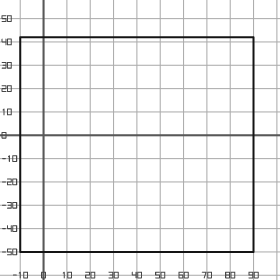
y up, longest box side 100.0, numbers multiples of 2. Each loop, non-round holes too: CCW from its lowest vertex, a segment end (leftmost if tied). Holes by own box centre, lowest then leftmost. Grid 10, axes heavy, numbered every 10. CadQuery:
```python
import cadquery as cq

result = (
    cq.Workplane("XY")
    .moveTo(-10.0, -50.0)
    .lineTo(90.0, -50.0)
    .lineTo(90.0, 42.0)
    .lineTo(-10.0, 42.0)
    .close()
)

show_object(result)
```